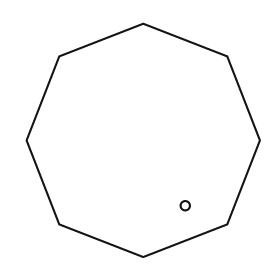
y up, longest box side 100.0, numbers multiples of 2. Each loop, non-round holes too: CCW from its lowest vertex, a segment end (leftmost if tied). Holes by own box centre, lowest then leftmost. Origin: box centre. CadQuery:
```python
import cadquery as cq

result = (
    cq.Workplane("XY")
    .moveTo(0.0, -50.0)
    .lineTo(36.0, -36.0)
    .lineTo(50.0, 0.0)
    .lineTo(36.0, 36.0)
    .lineTo(0.0, 50.0)
    .lineTo(-36.0, 36.0)
    .lineTo(-50.0, 0.0)
    .lineTo(-36.0, -36.0)
    .close()
    .moveTo(18.0, -28.0)
    .circle(2.0)
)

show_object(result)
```